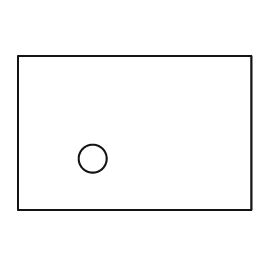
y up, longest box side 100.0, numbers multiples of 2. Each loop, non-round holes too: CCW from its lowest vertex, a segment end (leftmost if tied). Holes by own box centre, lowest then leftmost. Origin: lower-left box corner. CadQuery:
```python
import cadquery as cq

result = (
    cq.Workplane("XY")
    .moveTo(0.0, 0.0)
    .lineTo(100.0, 0.0)
    .lineTo(100.0, 66.0)
    .lineTo(0.0, 66.0)
    .close()
    .moveTo(32.0, 22.0)
    .circle(6.0)
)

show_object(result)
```